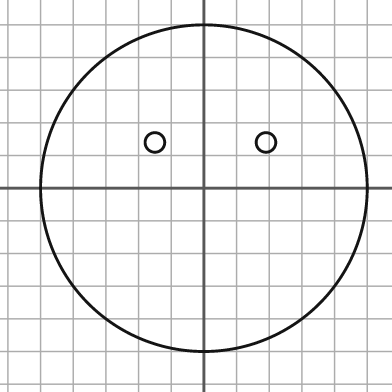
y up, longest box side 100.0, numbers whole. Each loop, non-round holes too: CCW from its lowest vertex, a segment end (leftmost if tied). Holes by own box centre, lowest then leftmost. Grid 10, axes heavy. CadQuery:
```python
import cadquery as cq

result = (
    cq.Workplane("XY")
    .moveTo(0.0, 0.0)
    .circle(50.0)
    .moveTo(-15.0, 14.0)
    .circle(3.0)
    .moveTo(19.0, 14.0)
    .circle(3.0)
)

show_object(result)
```